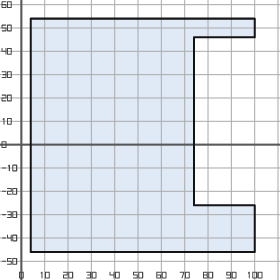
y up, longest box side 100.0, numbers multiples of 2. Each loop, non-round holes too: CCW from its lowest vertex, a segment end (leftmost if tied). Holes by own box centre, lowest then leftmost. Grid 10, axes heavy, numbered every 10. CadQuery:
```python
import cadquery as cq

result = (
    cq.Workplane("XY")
    .moveTo(4.0, -46.0)
    .lineTo(100.0, -46.0)
    .lineTo(100.0, -26.0)
    .lineTo(74.0, -26.0)
    .lineTo(74.0, 46.0)
    .lineTo(100.0, 46.0)
    .lineTo(100.0, 54.0)
    .lineTo(4.0, 54.0)
    .close()
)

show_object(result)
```